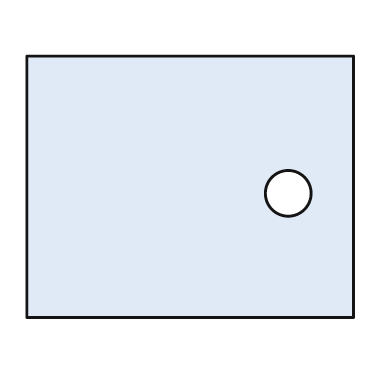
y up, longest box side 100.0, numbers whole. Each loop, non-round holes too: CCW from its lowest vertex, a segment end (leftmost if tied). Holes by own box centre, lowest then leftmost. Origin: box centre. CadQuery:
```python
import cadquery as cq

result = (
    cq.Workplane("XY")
    .moveTo(-50.0, -40.0)
    .lineTo(50.0, -40.0)
    .lineTo(50.0, 40.0)
    .lineTo(-50.0, 40.0)
    .close()
    .moveTo(30.0, -2.0)
    .circle(7.0)
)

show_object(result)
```